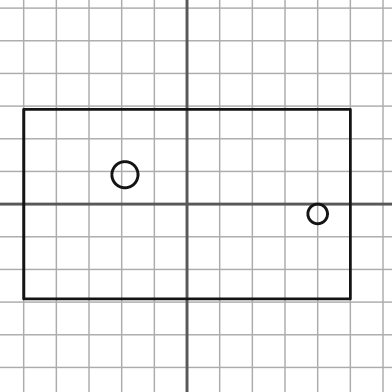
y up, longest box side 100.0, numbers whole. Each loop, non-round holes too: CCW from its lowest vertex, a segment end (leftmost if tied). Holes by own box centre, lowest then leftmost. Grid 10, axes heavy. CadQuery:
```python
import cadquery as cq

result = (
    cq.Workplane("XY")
    .moveTo(-50.0, -29.0)
    .lineTo(50.0, -29.0)
    .lineTo(50.0, 29.0)
    .lineTo(-50.0, 29.0)
    .close()
    .moveTo(40.0, -3.0)
    .circle(3.0)
    .moveTo(-19.0, 9.0)
    .circle(4.0)
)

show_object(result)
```